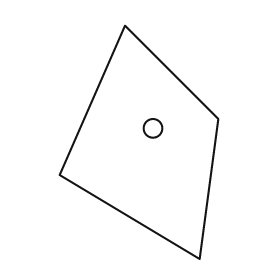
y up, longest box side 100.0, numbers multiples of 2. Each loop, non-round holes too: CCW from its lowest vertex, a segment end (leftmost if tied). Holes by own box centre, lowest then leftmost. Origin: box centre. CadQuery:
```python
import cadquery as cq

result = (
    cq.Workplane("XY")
    .moveTo(26.0, -50.0)
    .lineTo(34.0, 10.0)
    .lineTo(-6.0, 50.0)
    .lineTo(-34.0, -14.0)
    .close()
    .moveTo(6.0, 6.0)
    .circle(4.0)
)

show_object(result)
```